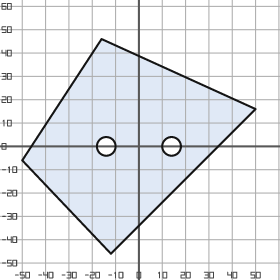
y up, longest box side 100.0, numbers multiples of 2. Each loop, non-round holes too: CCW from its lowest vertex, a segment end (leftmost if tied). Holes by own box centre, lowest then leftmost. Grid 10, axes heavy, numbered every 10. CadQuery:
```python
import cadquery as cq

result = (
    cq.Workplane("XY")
    .moveTo(-12.0, -46.0)
    .lineTo(50.0, 16.0)
    .lineTo(-16.0, 46.0)
    .lineTo(-50.0, -6.0)
    .close()
    .moveTo(-14.0, 0.0)
    .circle(4.0)
    .moveTo(14.0, 0.0)
    .circle(4.0)
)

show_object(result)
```